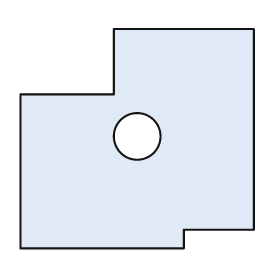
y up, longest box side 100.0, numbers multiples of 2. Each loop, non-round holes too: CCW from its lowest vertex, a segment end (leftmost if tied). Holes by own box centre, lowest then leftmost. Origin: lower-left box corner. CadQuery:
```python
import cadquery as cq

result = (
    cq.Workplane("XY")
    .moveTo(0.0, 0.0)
    .lineTo(70.0, 0.0)
    .lineTo(70.0, 8.0)
    .lineTo(100.0, 8.0)
    .lineTo(100.0, 94.0)
    .lineTo(40.0, 94.0)
    .lineTo(40.0, 66.0)
    .lineTo(0.0, 66.0)
    .close()
    .moveTo(50.0, 48.0)
    .circle(10.0)
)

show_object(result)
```